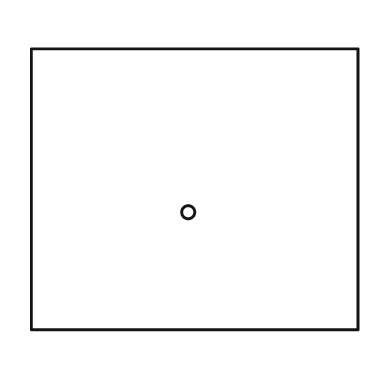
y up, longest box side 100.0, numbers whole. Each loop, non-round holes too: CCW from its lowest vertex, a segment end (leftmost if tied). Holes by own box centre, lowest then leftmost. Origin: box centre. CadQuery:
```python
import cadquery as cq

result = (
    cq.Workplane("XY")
    .moveTo(-50.0, -43.0)
    .lineTo(50.0, -43.0)
    .lineTo(50.0, 43.0)
    .lineTo(-50.0, 43.0)
    .close()
    .moveTo(-2.0, -7.0)
    .circle(2.0)
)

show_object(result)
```